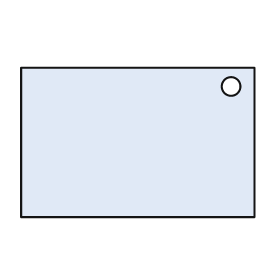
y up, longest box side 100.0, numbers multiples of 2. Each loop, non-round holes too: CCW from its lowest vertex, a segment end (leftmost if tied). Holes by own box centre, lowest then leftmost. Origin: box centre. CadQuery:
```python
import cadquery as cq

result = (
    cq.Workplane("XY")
    .moveTo(-50.0, -32.0)
    .lineTo(50.0, -32.0)
    .lineTo(50.0, 32.0)
    .lineTo(-50.0, 32.0)
    .close()
    .moveTo(40.0, 24.0)
    .circle(4.0)
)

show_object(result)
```